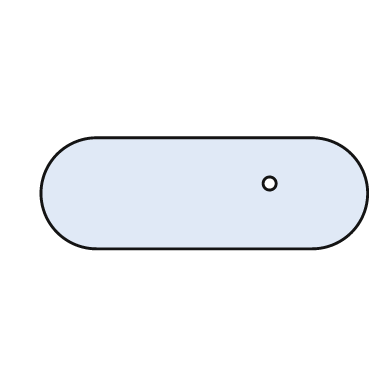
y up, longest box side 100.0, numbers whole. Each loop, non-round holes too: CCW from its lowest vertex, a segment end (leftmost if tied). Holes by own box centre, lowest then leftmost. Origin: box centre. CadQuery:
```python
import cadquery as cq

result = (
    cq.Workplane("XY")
    .moveTo(-33.0, -17.0)
    .lineTo(33.0, -17.0)
    .threePointArc((50.0, 0.0), (33.0, 17.0))
    .lineTo(-33.0, 17.0)
    .threePointArc((-50.0, 0.0), (-33.0, -17.0))
    .close()
    .moveTo(20.0, 3.0)
    .circle(2.0)
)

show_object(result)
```